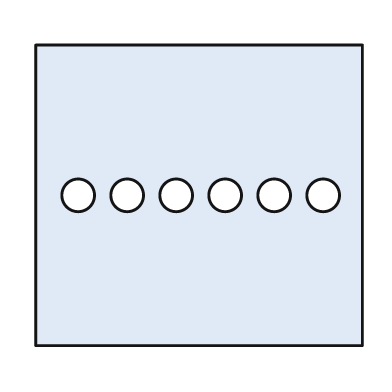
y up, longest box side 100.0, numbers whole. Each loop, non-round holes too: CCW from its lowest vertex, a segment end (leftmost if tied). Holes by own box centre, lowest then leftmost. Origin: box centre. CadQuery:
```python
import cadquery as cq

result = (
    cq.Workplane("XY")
    .moveTo(-50.0, -46.0)
    .lineTo(50.0, -46.0)
    .lineTo(50.0, 46.0)
    .lineTo(-50.0, 46.0)
    .close()
    .moveTo(-37.0, 0.0)
    .circle(5.0)
    .moveTo(-22.0, 0.0)
    .circle(5.0)
    .moveTo(-7.0, 0.0)
    .circle(5.0)
    .moveTo(8.0, 0.0)
    .circle(5.0)
    .moveTo(23.0, 0.0)
    .circle(5.0)
    .moveTo(38.0, 0.0)
    .circle(5.0)
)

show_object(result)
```